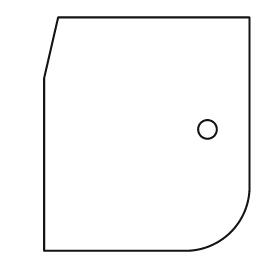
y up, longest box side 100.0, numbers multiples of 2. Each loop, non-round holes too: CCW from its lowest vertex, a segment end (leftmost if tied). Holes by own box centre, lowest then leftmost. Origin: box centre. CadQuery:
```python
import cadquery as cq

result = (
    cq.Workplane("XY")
    .moveTo(-44.0, -50.0)
    .lineTo(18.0, -50.0)
    .threePointArc((36.0, -42.0), (44.0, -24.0))
    .lineTo(44.0, 50.0)
    .lineTo(-38.0, 50.0)
    .lineTo(-44.0, 24.0)
    .close()
    .moveTo(26.0, 2.0)
    .circle(4.0)
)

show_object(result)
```